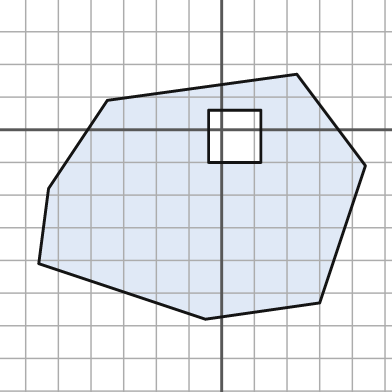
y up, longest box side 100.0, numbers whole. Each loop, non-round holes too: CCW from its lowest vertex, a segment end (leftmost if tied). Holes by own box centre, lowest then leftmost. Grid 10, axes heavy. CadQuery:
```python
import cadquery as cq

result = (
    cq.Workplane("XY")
    .moveTo(-5.0, -58.0)
    .lineTo(30.0, -53.0)
    .lineTo(44.0, -11.0)
    .lineTo(23.0, 17.0)
    .lineTo(-35.0, 9.0)
    .lineTo(-53.0, -18.0)
    .lineTo(-56.0, -41.0)
    .close()
    .moveTo(-4.0, -10.0)
    .lineTo(12.0, -10.0)
    .lineTo(12.0, 6.0)
    .lineTo(-4.0, 6.0)
    .close()
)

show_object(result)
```